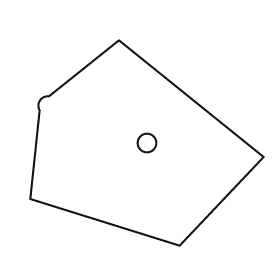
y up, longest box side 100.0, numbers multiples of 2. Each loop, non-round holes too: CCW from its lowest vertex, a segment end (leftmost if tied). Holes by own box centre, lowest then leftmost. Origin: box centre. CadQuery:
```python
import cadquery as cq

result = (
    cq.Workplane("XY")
    .moveTo(14.0, -44.0)
    .lineTo(50.0, -6.0)
    .lineTo(-12.0, 44.0)
    .lineTo(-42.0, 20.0)
    .threePointArc((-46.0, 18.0), (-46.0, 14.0))
    .lineTo(-50.0, -24.0)
    .close()
    .moveTo(0.0, 0.0)
    .circle(4.0)
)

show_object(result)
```